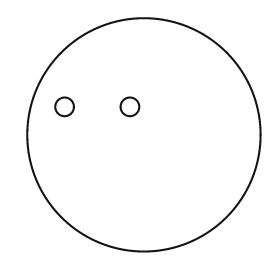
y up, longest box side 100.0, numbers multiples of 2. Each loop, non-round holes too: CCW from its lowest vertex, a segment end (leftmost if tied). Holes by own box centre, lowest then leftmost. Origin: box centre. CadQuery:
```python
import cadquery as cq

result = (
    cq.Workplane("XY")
    .moveTo(0.0, 0.0)
    .circle(50.0)
    .moveTo(-34.0, 12.0)
    .circle(4.0)
    .moveTo(-6.0, 12.0)
    .circle(4.0)
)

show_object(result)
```